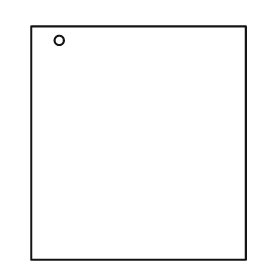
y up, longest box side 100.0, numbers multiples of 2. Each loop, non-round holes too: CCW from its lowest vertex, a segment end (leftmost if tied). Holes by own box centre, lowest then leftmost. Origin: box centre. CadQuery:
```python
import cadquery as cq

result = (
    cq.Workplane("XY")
    .moveTo(-46.0, -50.0)
    .lineTo(46.0, -50.0)
    .lineTo(46.0, 50.0)
    .lineTo(-46.0, 50.0)
    .close()
    .moveTo(-34.0, 44.0)
    .circle(2.0)
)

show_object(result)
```